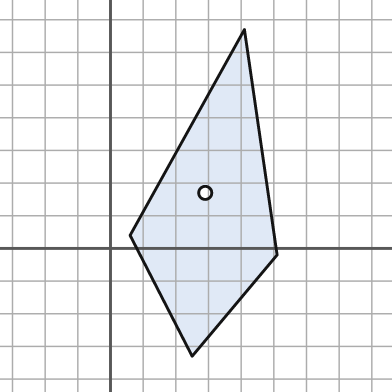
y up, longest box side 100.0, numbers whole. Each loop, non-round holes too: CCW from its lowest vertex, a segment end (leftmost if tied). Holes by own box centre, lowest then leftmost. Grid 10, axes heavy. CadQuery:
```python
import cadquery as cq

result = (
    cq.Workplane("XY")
    .moveTo(25.0, -33.0)
    .lineTo(51.0, -2.0)
    .lineTo(41.0, 67.0)
    .lineTo(6.0, 4.0)
    .close()
    .moveTo(29.0, 17.0)
    .circle(2.0)
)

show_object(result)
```